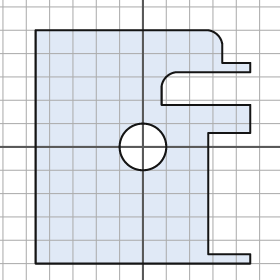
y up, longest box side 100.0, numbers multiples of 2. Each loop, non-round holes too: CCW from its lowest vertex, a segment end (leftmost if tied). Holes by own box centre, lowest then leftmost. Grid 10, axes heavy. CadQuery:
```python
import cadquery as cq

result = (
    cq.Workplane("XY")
    .moveTo(-46.0, -50.0)
    .lineTo(46.0, -50.0)
    .lineTo(46.0, -46.0)
    .lineTo(28.0, -46.0)
    .lineTo(28.0, 6.0)
    .lineTo(46.0, 6.0)
    .lineTo(46.0, 18.0)
    .lineTo(8.0, 18.0)
    .lineTo(8.0, 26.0)
    .threePointArc((10.0, 30.0), (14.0, 32.0))
    .lineTo(46.0, 32.0)
    .lineTo(46.0, 36.0)
    .lineTo(34.0, 36.0)
    .lineTo(34.0, 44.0)
    .threePointArc((32.0, 48.0), (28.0, 50.0))
    .lineTo(-46.0, 50.0)
    .close()
    .moveTo(0.0, 0.0)
    .circle(10.0)
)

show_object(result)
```